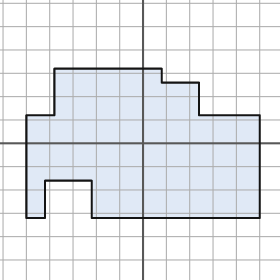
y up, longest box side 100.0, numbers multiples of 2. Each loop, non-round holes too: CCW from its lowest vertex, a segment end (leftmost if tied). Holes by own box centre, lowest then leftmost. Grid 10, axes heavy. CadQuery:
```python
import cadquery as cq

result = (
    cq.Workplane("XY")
    .moveTo(-50.0, -32.0)
    .lineTo(-42.0, -32.0)
    .lineTo(-42.0, -16.0)
    .lineTo(-22.0, -16.0)
    .lineTo(-22.0, -32.0)
    .lineTo(50.0, -32.0)
    .lineTo(50.0, 12.0)
    .lineTo(24.0, 12.0)
    .lineTo(24.0, 26.0)
    .lineTo(8.0, 26.0)
    .lineTo(8.0, 32.0)
    .lineTo(-38.0, 32.0)
    .lineTo(-38.0, 12.0)
    .lineTo(-50.0, 12.0)
    .close()
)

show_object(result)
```